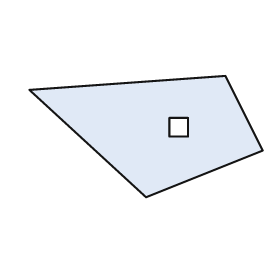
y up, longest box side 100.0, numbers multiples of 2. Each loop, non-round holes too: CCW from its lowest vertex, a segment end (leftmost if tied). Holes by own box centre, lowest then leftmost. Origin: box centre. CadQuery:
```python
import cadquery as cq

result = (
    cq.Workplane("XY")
    .moveTo(0.0, -26.0)
    .lineTo(50.0, -6.0)
    .lineTo(34.0, 26.0)
    .lineTo(-50.0, 20.0)
    .close()
    .moveTo(10.0, 0.0)
    .lineTo(18.0, 0.0)
    .lineTo(18.0, 8.0)
    .lineTo(10.0, 8.0)
    .close()
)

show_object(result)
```